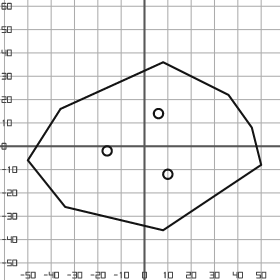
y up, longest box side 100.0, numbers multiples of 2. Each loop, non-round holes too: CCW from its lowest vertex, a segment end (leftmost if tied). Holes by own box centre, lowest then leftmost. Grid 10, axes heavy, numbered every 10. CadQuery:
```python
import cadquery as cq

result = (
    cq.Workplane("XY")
    .moveTo(8.0, -36.0)
    .lineTo(50.0, -8.0)
    .lineTo(46.0, 8.0)
    .lineTo(36.0, 22.0)
    .lineTo(8.0, 36.0)
    .lineTo(-36.0, 16.0)
    .lineTo(-50.0, -6.0)
    .lineTo(-34.0, -26.0)
    .close()
    .moveTo(10.0, -12.0)
    .circle(2.0)
    .moveTo(-16.0, -2.0)
    .circle(2.0)
    .moveTo(6.0, 14.0)
    .circle(2.0)
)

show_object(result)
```